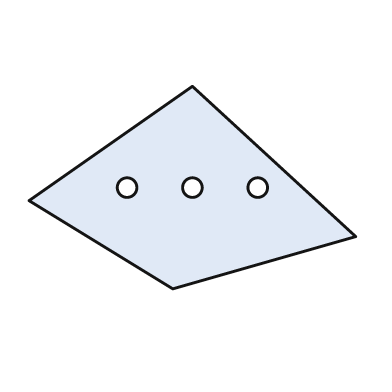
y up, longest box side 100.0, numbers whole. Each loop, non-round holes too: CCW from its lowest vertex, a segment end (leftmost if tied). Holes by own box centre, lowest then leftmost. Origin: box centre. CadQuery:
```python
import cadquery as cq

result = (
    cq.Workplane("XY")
    .moveTo(-6.0, -31.0)
    .lineTo(50.0, -15.0)
    .lineTo(0.0, 31.0)
    .lineTo(-50.0, -4.0)
    .close()
    .moveTo(-20.0, 0.0)
    .circle(3.0)
    .moveTo(0.0, 0.0)
    .circle(3.0)
    .moveTo(20.0, 0.0)
    .circle(3.0)
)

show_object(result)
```